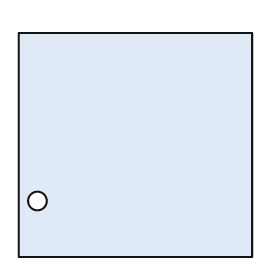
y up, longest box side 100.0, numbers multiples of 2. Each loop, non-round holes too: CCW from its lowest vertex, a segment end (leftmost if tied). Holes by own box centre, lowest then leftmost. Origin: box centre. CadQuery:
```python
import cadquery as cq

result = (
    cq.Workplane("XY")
    .moveTo(-50.0, -48.0)
    .lineTo(50.0, -48.0)
    .lineTo(50.0, 48.0)
    .lineTo(-50.0, 48.0)
    .close()
    .moveTo(-42.0, -24.0)
    .circle(4.0)
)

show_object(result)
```